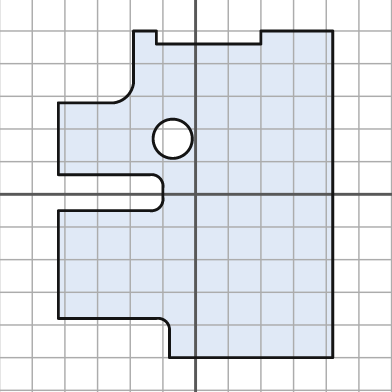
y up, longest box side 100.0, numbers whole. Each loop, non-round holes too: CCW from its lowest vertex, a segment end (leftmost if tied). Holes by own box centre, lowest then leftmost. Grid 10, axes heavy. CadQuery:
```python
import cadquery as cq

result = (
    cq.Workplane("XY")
    .moveTo(-8.0, -50.0)
    .lineTo(42.0, -50.0)
    .lineTo(42.0, 50.0)
    .lineTo(20.0, 50.0)
    .lineTo(20.0, 46.0)
    .lineTo(-12.0, 46.0)
    .lineTo(-12.0, 50.0)
    .lineTo(-19.0, 50.0)
    .lineTo(-19.0, 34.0)
    .threePointArc((-21.0, 30.0), (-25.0, 28.0))
    .lineTo(-42.0, 28.0)
    .lineTo(-42.0, 6.0)
    .lineTo(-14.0, 6.0)
    .threePointArc((-11.0, 5.0), (-10.0, 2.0))
    .lineTo(-10.0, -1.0)
    .threePointArc((-11.0, -4.0), (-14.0, -5.0))
    .lineTo(-42.0, -5.0)
    .lineTo(-42.0, -38.0)
    .lineTo(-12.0, -38.0)
    .threePointArc((-9.0, -39.0), (-8.0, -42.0))
    .close()
    .moveTo(-7.0, 17.0)
    .circle(6.0)
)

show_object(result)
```